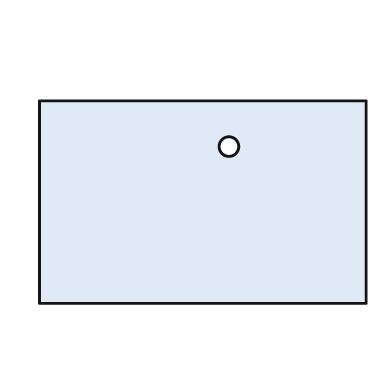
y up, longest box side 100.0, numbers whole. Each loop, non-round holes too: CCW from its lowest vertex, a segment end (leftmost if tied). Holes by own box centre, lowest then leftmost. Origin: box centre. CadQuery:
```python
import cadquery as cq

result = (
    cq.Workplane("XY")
    .moveTo(-50.0, -31.0)
    .lineTo(50.0, -31.0)
    .lineTo(50.0, 31.0)
    .lineTo(-50.0, 31.0)
    .close()
    .moveTo(8.0, 17.0)
    .circle(3.0)
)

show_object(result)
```